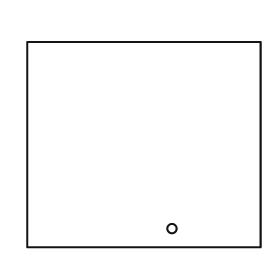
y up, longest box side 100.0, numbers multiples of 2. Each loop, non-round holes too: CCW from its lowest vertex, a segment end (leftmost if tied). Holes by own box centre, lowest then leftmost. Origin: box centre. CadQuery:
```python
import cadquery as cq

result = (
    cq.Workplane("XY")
    .moveTo(-50.0, -44.0)
    .lineTo(50.0, -44.0)
    .lineTo(50.0, 44.0)
    .lineTo(-50.0, 44.0)
    .close()
    .moveTo(12.0, -36.0)
    .circle(2.0)
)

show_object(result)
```